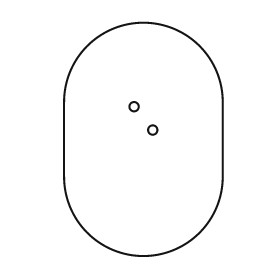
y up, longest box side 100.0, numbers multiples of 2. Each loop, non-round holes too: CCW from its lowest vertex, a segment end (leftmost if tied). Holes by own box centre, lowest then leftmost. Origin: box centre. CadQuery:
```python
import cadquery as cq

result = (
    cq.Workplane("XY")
    .moveTo(-34.0, -16.0)
    .threePointArc((0.0, -50.0), (34.0, -16.0))
    .lineTo(34.0, 16.0)
    .threePointArc((0.0, 50.0), (-34.0, 16.0))
    .close()
    .moveTo(4.0, 4.0)
    .circle(2.0)
    .moveTo(-4.0, 14.0)
    .circle(2.0)
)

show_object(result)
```